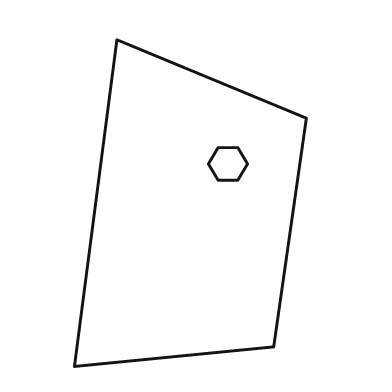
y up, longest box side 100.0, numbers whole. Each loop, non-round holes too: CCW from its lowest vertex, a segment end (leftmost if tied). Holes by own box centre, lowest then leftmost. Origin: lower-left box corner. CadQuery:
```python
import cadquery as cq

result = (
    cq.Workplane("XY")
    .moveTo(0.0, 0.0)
    .lineTo(61.0, 6.0)
    .lineTo(71.0, 76.0)
    .lineTo(13.0, 100.0)
    .close()
    .moveTo(44.0, 57.0)
    .lineTo(50.0, 57.0)
    .lineTo(53.0, 62.0)
    .lineTo(50.0, 67.0)
    .lineTo(44.0, 67.0)
    .lineTo(41.0, 62.0)
    .close()
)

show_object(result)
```